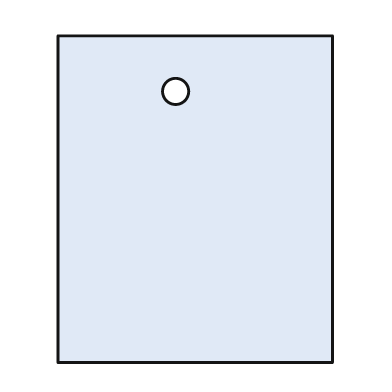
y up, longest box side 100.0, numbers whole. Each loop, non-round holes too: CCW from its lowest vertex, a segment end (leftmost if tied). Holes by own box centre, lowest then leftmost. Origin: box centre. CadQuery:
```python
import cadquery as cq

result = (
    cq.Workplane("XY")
    .moveTo(-42.0, -50.0)
    .lineTo(42.0, -50.0)
    .lineTo(42.0, 50.0)
    .lineTo(-42.0, 50.0)
    .close()
    .moveTo(-6.0, 33.0)
    .circle(4.0)
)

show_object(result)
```